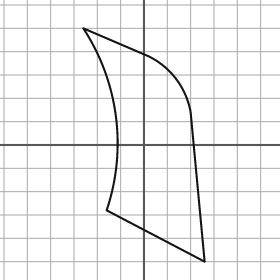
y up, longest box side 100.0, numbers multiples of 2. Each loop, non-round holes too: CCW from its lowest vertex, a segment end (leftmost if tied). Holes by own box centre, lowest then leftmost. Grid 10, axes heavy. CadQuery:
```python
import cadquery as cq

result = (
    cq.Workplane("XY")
    .moveTo(26.0, -50.0)
    .lineTo(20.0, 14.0)
    .threePointArc((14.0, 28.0), (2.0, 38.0))
    .lineTo(-26.0, 50.0)
    .threePointArc((-12.0, 12.0), (-16.0, -28.0))
    .close()
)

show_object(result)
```